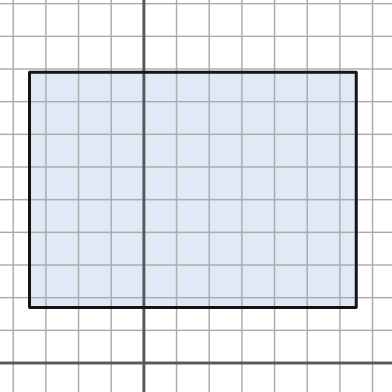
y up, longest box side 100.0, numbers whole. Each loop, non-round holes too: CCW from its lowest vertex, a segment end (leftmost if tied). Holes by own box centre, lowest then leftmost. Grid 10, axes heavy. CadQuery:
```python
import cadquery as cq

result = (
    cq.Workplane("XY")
    .moveTo(-35.0, 17.0)
    .lineTo(65.0, 17.0)
    .lineTo(65.0, 89.0)
    .lineTo(-35.0, 89.0)
    .close()
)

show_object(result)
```